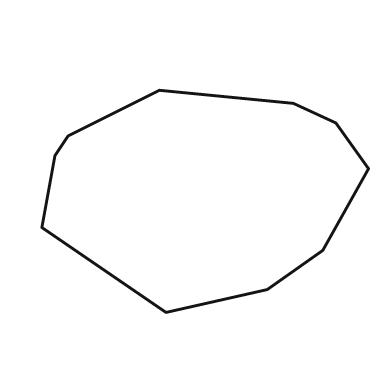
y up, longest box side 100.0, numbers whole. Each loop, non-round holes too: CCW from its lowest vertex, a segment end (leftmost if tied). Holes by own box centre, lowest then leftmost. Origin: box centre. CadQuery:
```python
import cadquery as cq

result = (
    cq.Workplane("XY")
    .moveTo(-12.0, -34.0)
    .lineTo(19.0, -27.0)
    .lineTo(36.0, -15.0)
    .lineTo(50.0, 10.0)
    .lineTo(40.0, 24.0)
    .lineTo(27.0, 30.0)
    .lineTo(-14.0, 34.0)
    .lineTo(-42.0, 20.0)
    .lineTo(-46.0, 14.0)
    .lineTo(-50.0, -8.0)
    .close()
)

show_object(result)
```